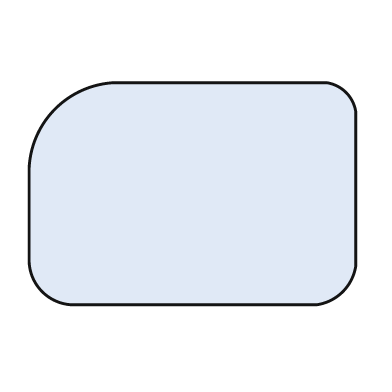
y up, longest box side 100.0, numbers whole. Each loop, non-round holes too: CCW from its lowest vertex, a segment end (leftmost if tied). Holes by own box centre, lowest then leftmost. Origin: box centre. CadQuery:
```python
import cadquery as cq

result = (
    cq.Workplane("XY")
    .moveTo(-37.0, -34.0)
    .lineTo(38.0, -34.0)
    .threePointArc((46.0, -30.0), (50.0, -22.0))
    .lineTo(50.0, 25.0)
    .threePointArc((47.0, 31.0), (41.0, 34.0))
    .lineTo(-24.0, 34.0)
    .threePointArc((-42.0, 26.0), (-50.0, 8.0))
    .lineTo(-50.0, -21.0)
    .threePointArc((-46.0, -30.0), (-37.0, -34.0))
    .close()
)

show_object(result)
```